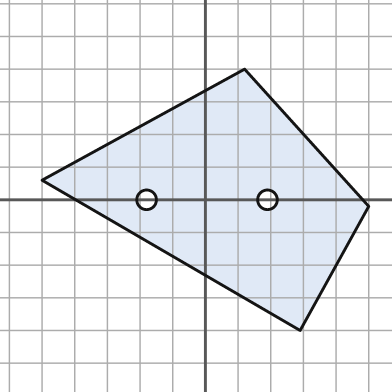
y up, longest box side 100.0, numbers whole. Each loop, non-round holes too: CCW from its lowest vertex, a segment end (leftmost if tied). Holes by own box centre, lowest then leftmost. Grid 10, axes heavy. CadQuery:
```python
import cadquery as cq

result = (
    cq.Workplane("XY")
    .moveTo(29.0, -40.0)
    .lineTo(50.0, -2.0)
    .lineTo(12.0, 40.0)
    .lineTo(-50.0, 6.0)
    .close()
    .moveTo(-18.0, 0.0)
    .circle(3.0)
    .moveTo(19.0, 0.0)
    .circle(3.0)
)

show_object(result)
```